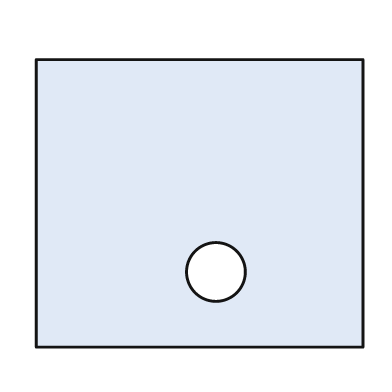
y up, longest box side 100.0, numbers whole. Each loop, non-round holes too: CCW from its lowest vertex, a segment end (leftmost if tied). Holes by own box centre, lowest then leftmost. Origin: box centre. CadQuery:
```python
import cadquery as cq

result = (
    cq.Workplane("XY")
    .moveTo(-50.0, -44.0)
    .lineTo(50.0, -44.0)
    .lineTo(50.0, 44.0)
    .lineTo(-50.0, 44.0)
    .close()
    .moveTo(5.0, -21.0)
    .circle(9.0)
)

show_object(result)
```